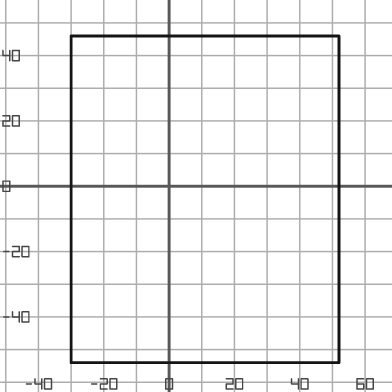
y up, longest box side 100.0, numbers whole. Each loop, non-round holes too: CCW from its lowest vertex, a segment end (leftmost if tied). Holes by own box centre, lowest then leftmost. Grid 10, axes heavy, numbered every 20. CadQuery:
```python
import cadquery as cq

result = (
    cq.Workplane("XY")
    .moveTo(-30.0, -54.0)
    .lineTo(52.0, -54.0)
    .lineTo(52.0, 46.0)
    .lineTo(-30.0, 46.0)
    .close()
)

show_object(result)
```